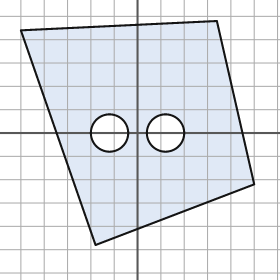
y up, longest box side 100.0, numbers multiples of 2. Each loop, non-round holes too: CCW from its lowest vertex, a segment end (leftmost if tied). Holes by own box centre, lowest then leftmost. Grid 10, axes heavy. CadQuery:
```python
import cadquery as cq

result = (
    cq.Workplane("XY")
    .moveTo(-18.0, -48.0)
    .lineTo(50.0, -22.0)
    .lineTo(34.0, 48.0)
    .lineTo(-50.0, 44.0)
    .close()
    .moveTo(-12.0, 0.0)
    .circle(8.0)
    .moveTo(12.0, 0.0)
    .circle(8.0)
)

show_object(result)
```